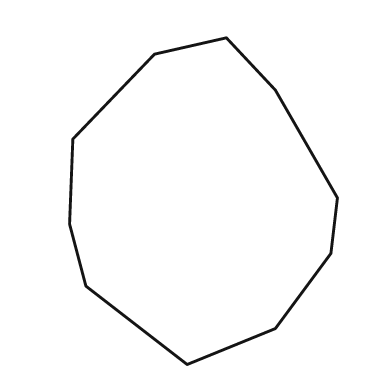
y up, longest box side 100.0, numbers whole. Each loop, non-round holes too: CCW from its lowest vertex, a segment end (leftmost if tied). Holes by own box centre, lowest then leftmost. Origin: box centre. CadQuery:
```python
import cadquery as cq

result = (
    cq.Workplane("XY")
    .moveTo(-5.0, -50.0)
    .lineTo(22.0, -39.0)
    .lineTo(39.0, -16.0)
    .lineTo(41.0, 1.0)
    .lineTo(22.0, 34.0)
    .lineTo(7.0, 50.0)
    .lineTo(-15.0, 45.0)
    .lineTo(-40.0, 19.0)
    .lineTo(-41.0, -7.0)
    .lineTo(-36.0, -26.0)
    .close()
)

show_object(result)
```